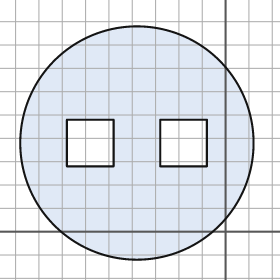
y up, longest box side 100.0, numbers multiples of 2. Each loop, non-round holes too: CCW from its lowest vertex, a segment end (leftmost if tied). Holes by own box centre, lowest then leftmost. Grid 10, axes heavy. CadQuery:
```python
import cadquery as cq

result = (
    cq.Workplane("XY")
    .moveTo(-38.0, 38.0)
    .circle(50.0)
    .moveTo(-68.0, 28.0)
    .lineTo(-48.0, 28.0)
    .lineTo(-48.0, 48.0)
    .lineTo(-68.0, 48.0)
    .close()
    .moveTo(-28.0, 28.0)
    .lineTo(-8.0, 28.0)
    .lineTo(-8.0, 48.0)
    .lineTo(-28.0, 48.0)
    .close()
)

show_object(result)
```